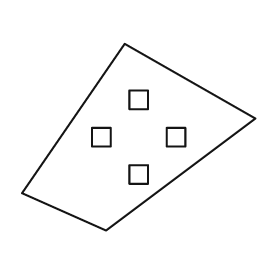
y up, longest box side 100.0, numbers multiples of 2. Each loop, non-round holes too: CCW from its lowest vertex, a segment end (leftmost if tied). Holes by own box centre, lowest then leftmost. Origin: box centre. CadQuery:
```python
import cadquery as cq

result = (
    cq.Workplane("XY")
    .moveTo(-14.0, -40.0)
    .lineTo(50.0, 8.0)
    .lineTo(-6.0, 40.0)
    .lineTo(-50.0, -24.0)
    .close()
    .moveTo(-4.0, -20.0)
    .lineTo(4.0, -20.0)
    .lineTo(4.0, -12.0)
    .lineTo(-4.0, -12.0)
    .close()
    .moveTo(-20.0, -4.0)
    .lineTo(-12.0, -4.0)
    .lineTo(-12.0, 4.0)
    .lineTo(-20.0, 4.0)
    .close()
    .moveTo(12.0, -4.0)
    .lineTo(20.0, -4.0)
    .lineTo(20.0, 4.0)
    .lineTo(12.0, 4.0)
    .close()
    .moveTo(-4.0, 12.0)
    .lineTo(4.0, 12.0)
    .lineTo(4.0, 20.0)
    .lineTo(-4.0, 20.0)
    .close()
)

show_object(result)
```